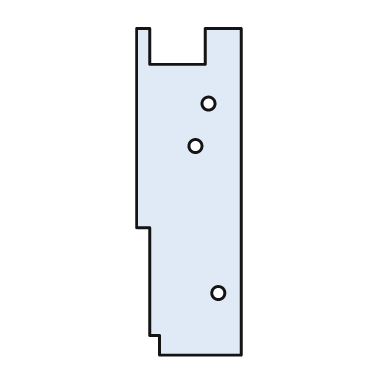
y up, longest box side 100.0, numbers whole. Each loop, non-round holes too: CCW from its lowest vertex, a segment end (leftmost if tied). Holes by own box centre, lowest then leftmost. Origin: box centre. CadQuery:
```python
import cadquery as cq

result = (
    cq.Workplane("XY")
    .moveTo(-9.0, -50.0)
    .lineTo(16.0, -50.0)
    .lineTo(16.0, 50.0)
    .lineTo(5.0, 50.0)
    .lineTo(5.0, 39.0)
    .lineTo(-12.0, 39.0)
    .lineTo(-12.0, 50.0)
    .lineTo(-16.0, 50.0)
    .lineTo(-16.0, -11.0)
    .lineTo(-12.0, -11.0)
    .lineTo(-12.0, -44.0)
    .lineTo(-9.0, -44.0)
    .close()
    .moveTo(9.0, -31.0)
    .circle(2.0)
    .moveTo(2.0, 14.0)
    .circle(2.0)
    .moveTo(6.0, 27.0)
    .circle(2.0)
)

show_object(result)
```